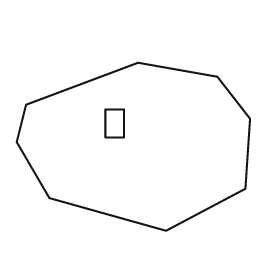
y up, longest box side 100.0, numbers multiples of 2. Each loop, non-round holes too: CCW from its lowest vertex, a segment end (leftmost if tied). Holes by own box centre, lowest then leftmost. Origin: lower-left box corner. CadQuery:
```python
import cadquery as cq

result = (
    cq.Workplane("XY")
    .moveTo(64.0, 0.0)
    .lineTo(98.0, 18.0)
    .lineTo(100.0, 48.0)
    .lineTo(86.0, 66.0)
    .lineTo(52.0, 72.0)
    .lineTo(4.0, 54.0)
    .lineTo(0.0, 38.0)
    .lineTo(14.0, 14.0)
    .close()
    .moveTo(38.0, 40.0)
    .lineTo(46.0, 40.0)
    .lineTo(46.0, 52.0)
    .lineTo(38.0, 52.0)
    .close()
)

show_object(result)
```